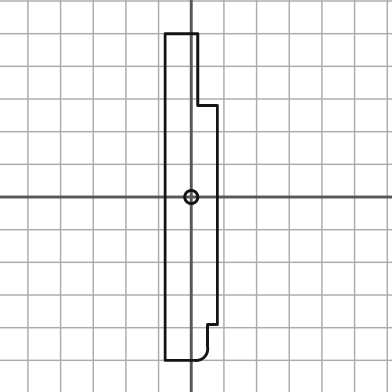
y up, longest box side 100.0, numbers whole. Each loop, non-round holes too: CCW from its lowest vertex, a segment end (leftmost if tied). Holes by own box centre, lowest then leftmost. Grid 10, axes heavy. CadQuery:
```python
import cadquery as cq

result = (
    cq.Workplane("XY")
    .moveTo(-8.0, -50.0)
    .lineTo(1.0, -50.0)
    .threePointArc((4.0, -49.0), (5.0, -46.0))
    .lineTo(5.0, -39.0)
    .lineTo(8.0, -39.0)
    .lineTo(8.0, 28.0)
    .lineTo(2.0, 28.0)
    .lineTo(2.0, 50.0)
    .lineTo(-8.0, 50.0)
    .close()
    .moveTo(0.0, 0.0)
    .circle(2.0)
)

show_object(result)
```